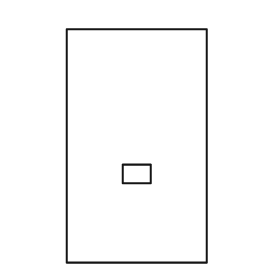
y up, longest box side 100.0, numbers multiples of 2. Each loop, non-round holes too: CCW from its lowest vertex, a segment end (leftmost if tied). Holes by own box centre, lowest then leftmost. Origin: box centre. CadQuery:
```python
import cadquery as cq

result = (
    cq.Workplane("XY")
    .moveTo(-30.0, -50.0)
    .lineTo(30.0, -50.0)
    .lineTo(30.0, 50.0)
    .lineTo(-30.0, 50.0)
    .close()
    .moveTo(-6.0, -16.0)
    .lineTo(6.0, -16.0)
    .lineTo(6.0, -8.0)
    .lineTo(-6.0, -8.0)
    .close()
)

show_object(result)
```